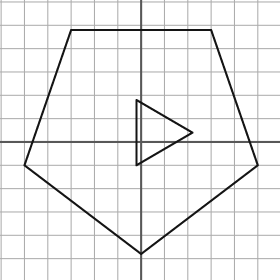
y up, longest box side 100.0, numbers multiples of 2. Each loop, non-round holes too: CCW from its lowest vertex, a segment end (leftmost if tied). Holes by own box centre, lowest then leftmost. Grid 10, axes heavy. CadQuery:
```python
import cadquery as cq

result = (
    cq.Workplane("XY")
    .moveTo(0.0, -48.0)
    .lineTo(50.0, -10.0)
    .lineTo(30.0, 48.0)
    .lineTo(-30.0, 48.0)
    .lineTo(-50.0, -10.0)
    .close()
    .moveTo(-2.0, -10.0)
    .lineTo(22.0, 4.0)
    .lineTo(-2.0, 18.0)
    .close()
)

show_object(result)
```